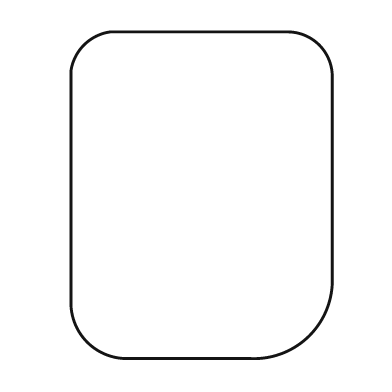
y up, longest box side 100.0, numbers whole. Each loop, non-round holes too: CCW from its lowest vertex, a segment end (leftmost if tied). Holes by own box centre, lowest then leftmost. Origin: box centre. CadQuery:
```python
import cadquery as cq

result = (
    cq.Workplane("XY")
    .moveTo(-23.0, -50.0)
    .lineTo(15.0, -50.0)
    .threePointArc((33.0, -43.0), (40.0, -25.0))
    .lineTo(40.0, 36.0)
    .threePointArc((36.0, 46.0), (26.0, 50.0))
    .lineTo(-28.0, 50.0)
    .threePointArc((-36.0, 46.0), (-40.0, 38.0))
    .lineTo(-40.0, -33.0)
    .threePointArc((-35.0, -45.0), (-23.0, -50.0))
    .close()
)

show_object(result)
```